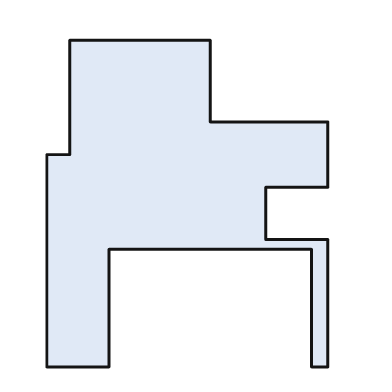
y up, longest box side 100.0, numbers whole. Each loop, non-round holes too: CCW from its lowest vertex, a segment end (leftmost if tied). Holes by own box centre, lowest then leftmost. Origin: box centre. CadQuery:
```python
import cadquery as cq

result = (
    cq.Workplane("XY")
    .moveTo(-43.0, -50.0)
    .lineTo(-24.0, -50.0)
    .lineTo(-24.0, -14.0)
    .lineTo(38.0, -14.0)
    .lineTo(38.0, -50.0)
    .lineTo(43.0, -50.0)
    .lineTo(43.0, -11.0)
    .lineTo(24.0, -11.0)
    .lineTo(24.0, 5.0)
    .lineTo(43.0, 5.0)
    .lineTo(43.0, 25.0)
    .lineTo(7.0, 25.0)
    .lineTo(7.0, 50.0)
    .lineTo(-36.0, 50.0)
    .lineTo(-36.0, 15.0)
    .lineTo(-43.0, 15.0)
    .close()
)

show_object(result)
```